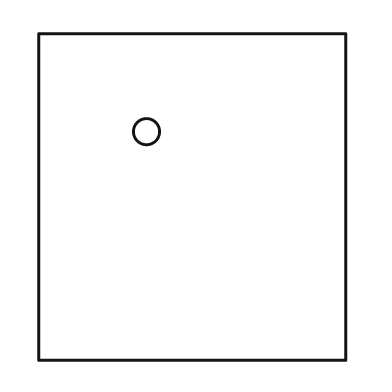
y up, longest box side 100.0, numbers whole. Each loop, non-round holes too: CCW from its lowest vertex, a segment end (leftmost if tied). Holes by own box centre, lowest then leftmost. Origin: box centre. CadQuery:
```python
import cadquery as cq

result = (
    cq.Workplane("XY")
    .moveTo(-47.0, -50.0)
    .lineTo(47.0, -50.0)
    .lineTo(47.0, 50.0)
    .lineTo(-47.0, 50.0)
    .close()
    .moveTo(-14.0, 20.0)
    .circle(4.0)
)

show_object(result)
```